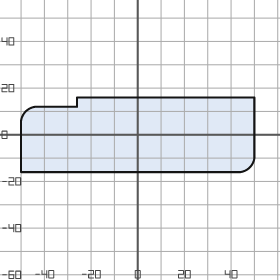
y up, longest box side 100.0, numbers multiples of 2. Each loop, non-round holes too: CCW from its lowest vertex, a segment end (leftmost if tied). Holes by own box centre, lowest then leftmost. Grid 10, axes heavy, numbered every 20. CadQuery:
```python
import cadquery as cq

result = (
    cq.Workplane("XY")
    .moveTo(-50.0, -16.0)
    .lineTo(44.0, -16.0)
    .threePointArc((48.0, -14.0), (50.0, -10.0))
    .lineTo(50.0, 16.0)
    .lineTo(-26.0, 16.0)
    .lineTo(-26.0, 12.0)
    .lineTo(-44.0, 12.0)
    .threePointArc((-48.0, 10.0), (-50.0, 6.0))
    .close()
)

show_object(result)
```